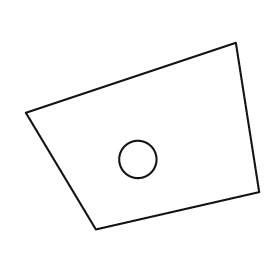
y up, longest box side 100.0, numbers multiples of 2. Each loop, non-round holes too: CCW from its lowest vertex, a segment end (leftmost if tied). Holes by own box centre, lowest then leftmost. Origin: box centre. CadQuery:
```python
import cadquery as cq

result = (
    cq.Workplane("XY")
    .moveTo(-20.0, -40.0)
    .lineTo(50.0, -24.0)
    .lineTo(40.0, 40.0)
    .lineTo(-50.0, 10.0)
    .close()
    .moveTo(-2.0, -10.0)
    .circle(8.0)
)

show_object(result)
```